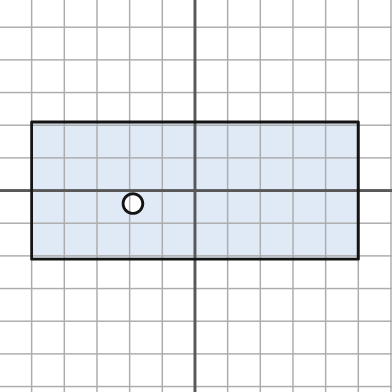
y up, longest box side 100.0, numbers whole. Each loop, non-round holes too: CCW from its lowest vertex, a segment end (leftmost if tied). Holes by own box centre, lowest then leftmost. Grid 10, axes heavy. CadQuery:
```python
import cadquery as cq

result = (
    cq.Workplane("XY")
    .moveTo(-50.0, -21.0)
    .lineTo(50.0, -21.0)
    .lineTo(50.0, 21.0)
    .lineTo(-50.0, 21.0)
    .close()
    .moveTo(-19.0, -4.0)
    .circle(3.0)
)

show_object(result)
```